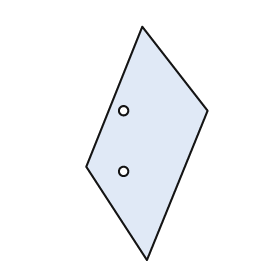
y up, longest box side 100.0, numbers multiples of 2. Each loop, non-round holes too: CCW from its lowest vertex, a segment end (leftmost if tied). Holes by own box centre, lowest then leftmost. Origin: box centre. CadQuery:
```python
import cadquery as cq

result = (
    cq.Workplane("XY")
    .moveTo(0.0, -50.0)
    .lineTo(26.0, 14.0)
    .lineTo(-2.0, 50.0)
    .lineTo(-26.0, -10.0)
    .close()
    .moveTo(-10.0, -12.0)
    .circle(2.0)
    .moveTo(-10.0, 14.0)
    .circle(2.0)
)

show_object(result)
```